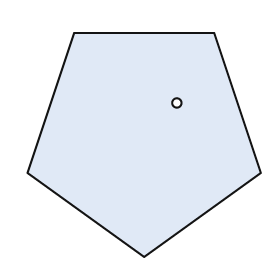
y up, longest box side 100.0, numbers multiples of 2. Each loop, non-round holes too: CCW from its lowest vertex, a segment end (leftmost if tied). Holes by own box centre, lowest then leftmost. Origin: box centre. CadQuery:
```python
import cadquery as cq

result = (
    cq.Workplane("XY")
    .moveTo(0.0, -48.0)
    .lineTo(50.0, -12.0)
    .lineTo(30.0, 48.0)
    .lineTo(-30.0, 48.0)
    .lineTo(-50.0, -12.0)
    .close()
    .moveTo(14.0, 18.0)
    .circle(2.0)
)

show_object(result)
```